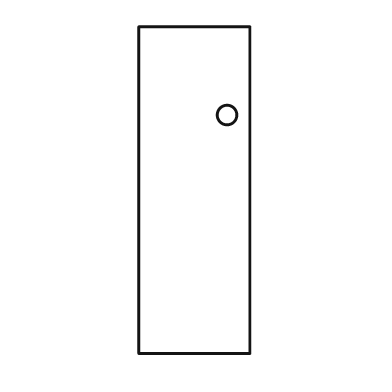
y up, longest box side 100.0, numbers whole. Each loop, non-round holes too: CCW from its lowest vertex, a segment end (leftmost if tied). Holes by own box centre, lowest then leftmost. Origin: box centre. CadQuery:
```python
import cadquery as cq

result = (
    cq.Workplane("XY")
    .moveTo(-17.0, -50.0)
    .lineTo(17.0, -50.0)
    .lineTo(17.0, 50.0)
    .lineTo(-17.0, 50.0)
    .close()
    .moveTo(10.0, 23.0)
    .circle(3.0)
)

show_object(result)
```